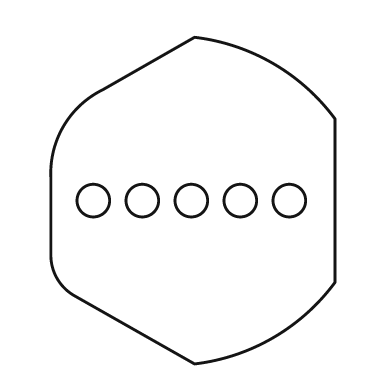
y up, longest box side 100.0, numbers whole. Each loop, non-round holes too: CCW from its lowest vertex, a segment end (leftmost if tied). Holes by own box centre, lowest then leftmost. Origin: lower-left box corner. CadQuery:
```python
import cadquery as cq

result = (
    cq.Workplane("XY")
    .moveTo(44.0, 0.0)
    .threePointArc((68.0, 8.0), (87.0, 25.0))
    .lineTo(87.0, 75.0)
    .threePointArc((68.0, 92.0), (44.0, 100.0))
    .lineTo(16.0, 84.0)
    .threePointArc((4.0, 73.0), (0.0, 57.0))
    .lineTo(0.0, 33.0)
    .threePointArc((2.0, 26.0), (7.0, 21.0))
    .close()
    .moveTo(13.0, 50.0)
    .circle(5.0)
    .moveTo(28.0, 50.0)
    .circle(5.0)
    .moveTo(43.0, 50.0)
    .circle(5.0)
    .moveTo(58.0, 50.0)
    .circle(5.0)
    .moveTo(73.0, 50.0)
    .circle(5.0)
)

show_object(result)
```